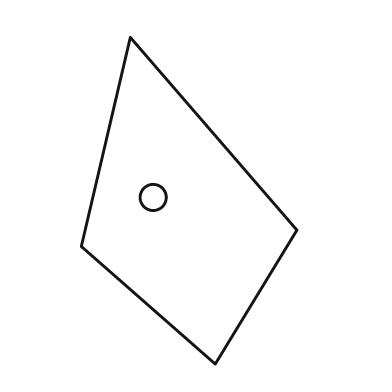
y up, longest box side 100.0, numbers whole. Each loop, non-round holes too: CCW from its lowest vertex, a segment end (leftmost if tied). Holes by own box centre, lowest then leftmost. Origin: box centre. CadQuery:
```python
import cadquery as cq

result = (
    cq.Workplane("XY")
    .moveTo(8.0, -50.0)
    .lineTo(33.0, -9.0)
    .lineTo(-18.0, 50.0)
    .lineTo(-33.0, -14.0)
    .close()
    .moveTo(-11.0, 1.0)
    .circle(4.0)
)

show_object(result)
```